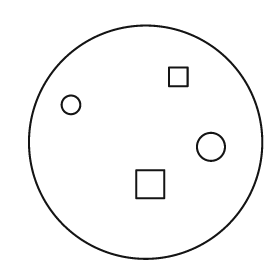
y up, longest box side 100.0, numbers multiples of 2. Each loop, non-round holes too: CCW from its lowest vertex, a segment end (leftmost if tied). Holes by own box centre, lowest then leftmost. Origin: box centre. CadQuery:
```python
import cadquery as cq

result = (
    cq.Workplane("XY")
    .moveTo(0.0, 0.0)
    .circle(50.0)
    .moveTo(-4.0, -24.0)
    .lineTo(8.0, -24.0)
    .lineTo(8.0, -12.0)
    .lineTo(-4.0, -12.0)
    .close()
    .moveTo(28.0, -2.0)
    .circle(6.0)
    .moveTo(-32.0, 16.0)
    .circle(4.0)
    .moveTo(10.0, 24.0)
    .lineTo(18.0, 24.0)
    .lineTo(18.0, 32.0)
    .lineTo(10.0, 32.0)
    .close()
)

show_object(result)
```